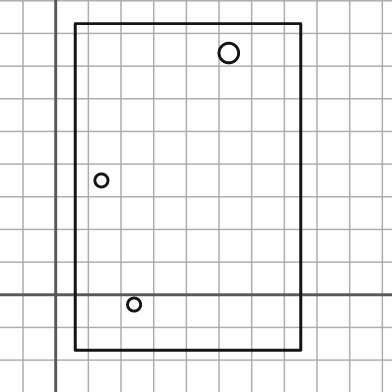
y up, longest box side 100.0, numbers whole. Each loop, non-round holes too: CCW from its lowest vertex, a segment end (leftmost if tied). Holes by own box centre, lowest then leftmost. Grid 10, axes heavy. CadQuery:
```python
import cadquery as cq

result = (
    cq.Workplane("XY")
    .moveTo(6.0, -17.0)
    .lineTo(75.0, -17.0)
    .lineTo(75.0, 83.0)
    .lineTo(6.0, 83.0)
    .close()
    .moveTo(24.0, -3.0)
    .circle(2.0)
    .moveTo(14.0, 35.0)
    .circle(2.0)
    .moveTo(53.0, 74.0)
    .circle(3.0)
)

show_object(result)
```